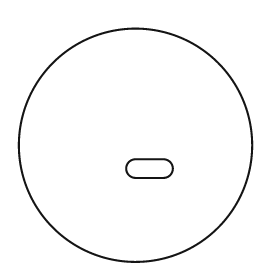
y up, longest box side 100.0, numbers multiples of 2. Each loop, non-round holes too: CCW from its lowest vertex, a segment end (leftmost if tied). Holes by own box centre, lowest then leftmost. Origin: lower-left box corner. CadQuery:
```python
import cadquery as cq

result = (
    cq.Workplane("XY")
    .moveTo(50.0, 50.0)
    .circle(50.0)
    .moveTo(50.0, 36.0)
    .lineTo(62.0, 36.0)
    .threePointArc((66.0, 40.0), (62.0, 44.0))
    .lineTo(50.0, 44.0)
    .threePointArc((46.0, 40.0), (50.0, 36.0))
    .close()
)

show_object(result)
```